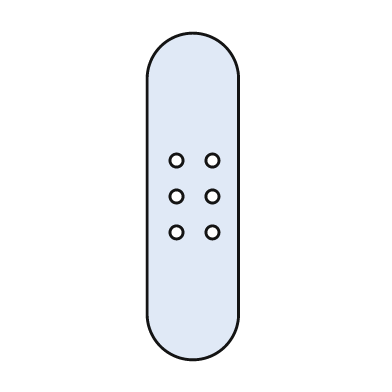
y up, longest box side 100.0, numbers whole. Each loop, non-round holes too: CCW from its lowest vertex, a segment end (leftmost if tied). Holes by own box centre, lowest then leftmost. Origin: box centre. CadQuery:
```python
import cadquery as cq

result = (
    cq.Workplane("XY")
    .moveTo(-14.0, -36.0)
    .threePointArc((0.0, -50.0), (14.0, -36.0))
    .lineTo(14.0, 36.0)
    .threePointArc((0.0, 50.0), (-14.0, 36.0))
    .close()
    .moveTo(-5.0, -11.0)
    .circle(2.0)
    .moveTo(6.0, -11.0)
    .circle(2.0)
    .moveTo(-5.0, 0.0)
    .circle(2.0)
    .moveTo(6.0, 0.0)
    .circle(2.0)
    .moveTo(-5.0, 11.0)
    .circle(2.0)
    .moveTo(6.0, 11.0)
    .circle(2.0)
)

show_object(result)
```